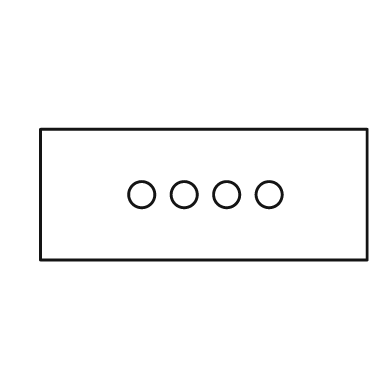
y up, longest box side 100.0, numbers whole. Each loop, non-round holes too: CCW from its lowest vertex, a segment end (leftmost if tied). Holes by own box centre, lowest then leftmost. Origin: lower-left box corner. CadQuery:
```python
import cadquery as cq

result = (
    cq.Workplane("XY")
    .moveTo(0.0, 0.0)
    .lineTo(100.0, 0.0)
    .lineTo(100.0, 40.0)
    .lineTo(0.0, 40.0)
    .close()
    .moveTo(31.0, 20.0)
    .circle(4.0)
    .moveTo(44.0, 20.0)
    .circle(4.0)
    .moveTo(57.0, 20.0)
    .circle(4.0)
    .moveTo(70.0, 20.0)
    .circle(4.0)
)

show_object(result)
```